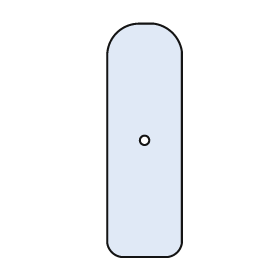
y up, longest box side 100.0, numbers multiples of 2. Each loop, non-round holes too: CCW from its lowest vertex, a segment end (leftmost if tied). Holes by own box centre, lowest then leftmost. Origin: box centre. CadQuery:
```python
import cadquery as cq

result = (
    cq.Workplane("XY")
    .moveTo(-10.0, -50.0)
    .lineTo(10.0, -50.0)
    .threePointArc((14.0, -48.0), (16.0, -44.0))
    .lineTo(16.0, 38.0)
    .threePointArc((12.0, 46.0), (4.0, 50.0))
    .lineTo(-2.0, 50.0)
    .threePointArc((-12.0, 46.0), (-16.0, 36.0))
    .lineTo(-16.0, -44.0)
    .threePointArc((-14.0, -48.0), (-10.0, -50.0))
    .close()
    .moveTo(0.0, 0.0)
    .circle(2.0)
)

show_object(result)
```